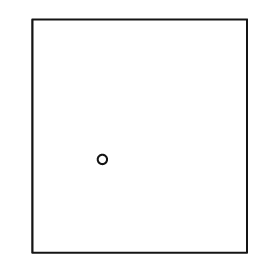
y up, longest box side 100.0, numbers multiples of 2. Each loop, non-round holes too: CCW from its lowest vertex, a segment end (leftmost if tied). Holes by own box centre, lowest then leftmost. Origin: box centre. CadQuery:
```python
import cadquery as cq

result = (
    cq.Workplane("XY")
    .moveTo(-46.0, -50.0)
    .lineTo(46.0, -50.0)
    .lineTo(46.0, 50.0)
    .lineTo(-46.0, 50.0)
    .close()
    .moveTo(-16.0, -10.0)
    .circle(2.0)
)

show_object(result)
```